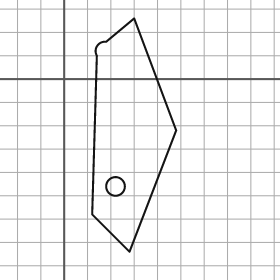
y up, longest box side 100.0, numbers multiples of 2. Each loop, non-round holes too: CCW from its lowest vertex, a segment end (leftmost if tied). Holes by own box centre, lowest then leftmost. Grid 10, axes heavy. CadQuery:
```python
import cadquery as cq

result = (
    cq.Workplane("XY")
    .moveTo(28.0, -74.0)
    .lineTo(48.0, -22.0)
    .lineTo(30.0, 26.0)
    .lineTo(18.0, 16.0)
    .threePointArc((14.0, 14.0), (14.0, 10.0))
    .lineTo(12.0, -58.0)
    .close()
    .moveTo(22.0, -46.0)
    .circle(4.0)
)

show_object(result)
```